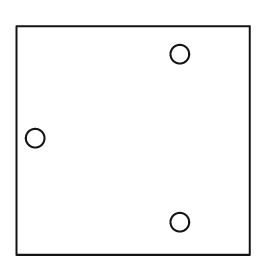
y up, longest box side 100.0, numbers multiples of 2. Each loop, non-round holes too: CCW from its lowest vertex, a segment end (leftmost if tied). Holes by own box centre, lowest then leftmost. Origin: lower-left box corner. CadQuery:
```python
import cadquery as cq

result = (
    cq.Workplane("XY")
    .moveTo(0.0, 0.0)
    .lineTo(100.0, 0.0)
    .lineTo(100.0, 98.0)
    .lineTo(0.0, 98.0)
    .close()
    .moveTo(70.0, 14.0)
    .circle(4.0)
    .moveTo(8.0, 50.0)
    .circle(4.0)
    .moveTo(70.0, 86.0)
    .circle(4.0)
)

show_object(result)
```